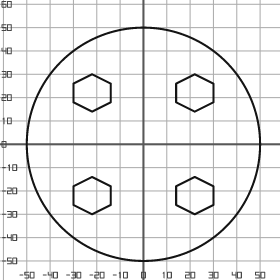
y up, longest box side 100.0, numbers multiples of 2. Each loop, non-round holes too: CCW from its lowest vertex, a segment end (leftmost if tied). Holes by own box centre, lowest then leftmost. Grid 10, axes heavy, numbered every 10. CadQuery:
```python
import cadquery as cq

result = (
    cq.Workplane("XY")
    .moveTo(0.0, 0.0)
    .circle(50.0)
    .moveTo(-22.0, -30.0)
    .lineTo(-14.0, -26.0)
    .lineTo(-14.0, -18.0)
    .lineTo(-22.0, -14.0)
    .lineTo(-30.0, -18.0)
    .lineTo(-30.0, -26.0)
    .close()
    .moveTo(22.0, -30.0)
    .lineTo(30.0, -26.0)
    .lineTo(30.0, -18.0)
    .lineTo(22.0, -14.0)
    .lineTo(14.0, -18.0)
    .lineTo(14.0, -26.0)
    .close()
    .moveTo(-22.0, 14.0)
    .lineTo(-14.0, 18.0)
    .lineTo(-14.0, 26.0)
    .lineTo(-22.0, 30.0)
    .lineTo(-30.0, 26.0)
    .lineTo(-30.0, 18.0)
    .close()
    .moveTo(22.0, 14.0)
    .lineTo(30.0, 18.0)
    .lineTo(30.0, 26.0)
    .lineTo(22.0, 30.0)
    .lineTo(14.0, 26.0)
    .lineTo(14.0, 18.0)
    .close()
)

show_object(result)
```